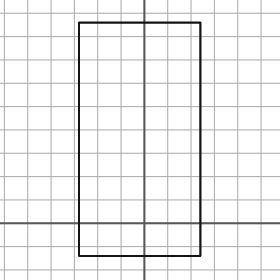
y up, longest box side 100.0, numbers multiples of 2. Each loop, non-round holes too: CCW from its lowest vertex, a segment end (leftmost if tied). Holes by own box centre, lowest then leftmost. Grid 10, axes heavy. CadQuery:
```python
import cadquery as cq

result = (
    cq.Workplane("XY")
    .moveTo(-28.0, -14.0)
    .lineTo(24.0, -14.0)
    .lineTo(24.0, 86.0)
    .lineTo(-28.0, 86.0)
    .close()
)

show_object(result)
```